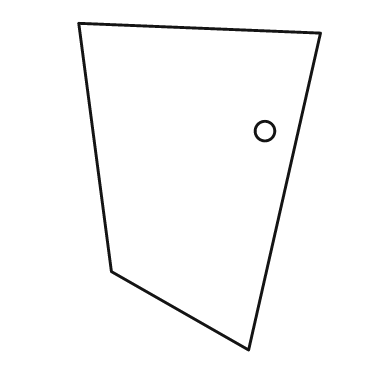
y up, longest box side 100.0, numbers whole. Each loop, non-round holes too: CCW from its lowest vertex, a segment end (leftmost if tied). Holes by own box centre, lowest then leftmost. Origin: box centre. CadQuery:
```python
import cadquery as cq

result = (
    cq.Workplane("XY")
    .moveTo(15.0, -50.0)
    .lineTo(37.0, 47.0)
    .lineTo(-37.0, 50.0)
    .lineTo(-27.0, -26.0)
    .close()
    .moveTo(20.0, 17.0)
    .circle(3.0)
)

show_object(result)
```